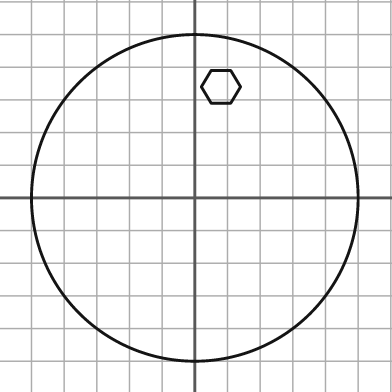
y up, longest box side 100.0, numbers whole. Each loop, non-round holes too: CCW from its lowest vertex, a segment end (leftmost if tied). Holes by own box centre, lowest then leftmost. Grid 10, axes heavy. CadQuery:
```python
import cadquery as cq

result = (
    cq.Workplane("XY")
    .moveTo(0.0, 0.0)
    .circle(50.0)
    .moveTo(5.0, 29.0)
    .lineTo(11.0, 29.0)
    .lineTo(14.0, 34.0)
    .lineTo(11.0, 39.0)
    .lineTo(5.0, 39.0)
    .lineTo(2.0, 34.0)
    .close()
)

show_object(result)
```